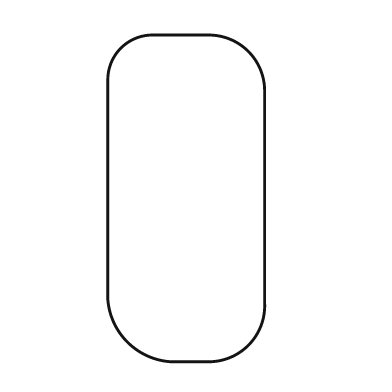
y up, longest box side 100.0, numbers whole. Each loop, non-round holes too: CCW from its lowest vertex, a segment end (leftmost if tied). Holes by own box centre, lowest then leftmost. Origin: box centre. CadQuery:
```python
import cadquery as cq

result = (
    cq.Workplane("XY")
    .moveTo(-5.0, -50.0)
    .lineTo(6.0, -50.0)
    .threePointArc((19.0, -45.0), (24.0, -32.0))
    .lineTo(24.0, 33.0)
    .threePointArc((19.0, 45.0), (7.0, 50.0))
    .lineTo(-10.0, 50.0)
    .threePointArc((-20.0, 46.0), (-24.0, 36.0))
    .lineTo(-24.0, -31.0)
    .threePointArc((-18.0, -44.0), (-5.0, -50.0))
    .close()
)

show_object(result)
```